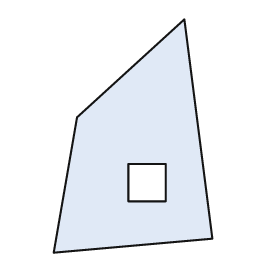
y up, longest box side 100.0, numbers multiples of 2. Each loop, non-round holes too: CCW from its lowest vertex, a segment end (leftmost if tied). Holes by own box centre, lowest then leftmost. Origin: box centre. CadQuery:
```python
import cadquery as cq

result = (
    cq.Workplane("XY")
    .moveTo(-34.0, -50.0)
    .lineTo(34.0, -44.0)
    .lineTo(22.0, 50.0)
    .lineTo(-24.0, 8.0)
    .close()
    .moveTo(-2.0, -28.0)
    .lineTo(14.0, -28.0)
    .lineTo(14.0, -12.0)
    .lineTo(-2.0, -12.0)
    .close()
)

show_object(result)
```